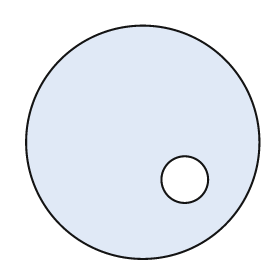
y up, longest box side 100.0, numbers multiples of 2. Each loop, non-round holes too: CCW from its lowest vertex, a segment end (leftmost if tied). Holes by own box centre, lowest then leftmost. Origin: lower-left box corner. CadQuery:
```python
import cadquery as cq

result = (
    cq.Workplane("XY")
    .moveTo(50.0, 50.0)
    .circle(50.0)
    .moveTo(68.0, 34.0)
    .circle(10.0)
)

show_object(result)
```